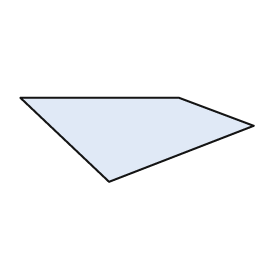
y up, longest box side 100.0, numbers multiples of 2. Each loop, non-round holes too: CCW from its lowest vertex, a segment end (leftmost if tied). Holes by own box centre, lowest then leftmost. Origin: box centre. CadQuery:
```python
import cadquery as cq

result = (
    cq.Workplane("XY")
    .moveTo(-12.0, -18.0)
    .lineTo(50.0, 6.0)
    .lineTo(18.0, 18.0)
    .lineTo(-50.0, 18.0)
    .close()
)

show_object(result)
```